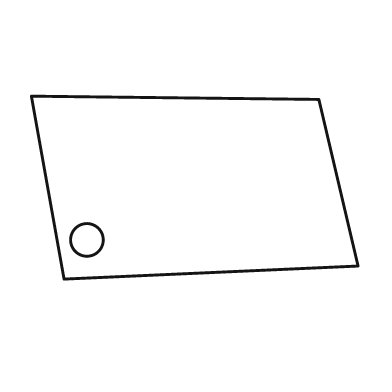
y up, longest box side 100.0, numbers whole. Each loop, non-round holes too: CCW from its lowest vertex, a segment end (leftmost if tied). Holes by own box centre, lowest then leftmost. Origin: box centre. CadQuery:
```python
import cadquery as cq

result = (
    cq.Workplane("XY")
    .moveTo(-40.0, -28.0)
    .lineTo(50.0, -24.0)
    .lineTo(38.0, 27.0)
    .lineTo(-50.0, 28.0)
    .close()
    .moveTo(-33.0, -16.0)
    .circle(5.0)
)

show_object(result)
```